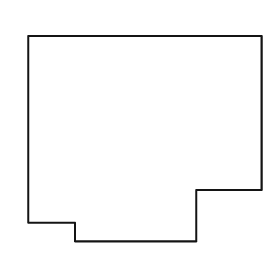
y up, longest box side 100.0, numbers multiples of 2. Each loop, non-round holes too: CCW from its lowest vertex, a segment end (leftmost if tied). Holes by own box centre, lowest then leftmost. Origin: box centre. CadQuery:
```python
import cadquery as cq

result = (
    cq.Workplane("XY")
    .moveTo(-30.0, -44.0)
    .lineTo(22.0, -44.0)
    .lineTo(22.0, -22.0)
    .lineTo(50.0, -22.0)
    .lineTo(50.0, 44.0)
    .lineTo(-50.0, 44.0)
    .lineTo(-50.0, -36.0)
    .lineTo(-30.0, -36.0)
    .close()
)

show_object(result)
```